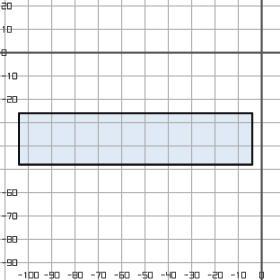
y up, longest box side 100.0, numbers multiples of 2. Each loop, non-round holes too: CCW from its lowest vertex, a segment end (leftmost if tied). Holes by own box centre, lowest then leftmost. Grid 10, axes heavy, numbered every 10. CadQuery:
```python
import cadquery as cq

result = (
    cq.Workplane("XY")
    .moveTo(-104.0, -48.0)
    .lineTo(-4.0, -48.0)
    .lineTo(-4.0, -26.0)
    .lineTo(-104.0, -26.0)
    .close()
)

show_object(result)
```